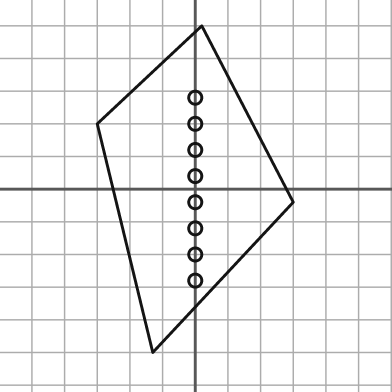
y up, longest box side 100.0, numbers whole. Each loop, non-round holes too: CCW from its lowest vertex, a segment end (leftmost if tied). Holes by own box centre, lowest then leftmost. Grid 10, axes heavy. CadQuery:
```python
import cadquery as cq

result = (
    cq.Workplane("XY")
    .moveTo(-13.0, -50.0)
    .lineTo(30.0, -4.0)
    .lineTo(2.0, 50.0)
    .lineTo(-30.0, 20.0)
    .close()
    .moveTo(0.0, -28.0)
    .circle(2.0)
    .moveTo(0.0, -20.0)
    .circle(2.0)
    .moveTo(0.0, -12.0)
    .circle(2.0)
    .moveTo(0.0, -4.0)
    .circle(2.0)
    .moveTo(0.0, 4.0)
    .circle(2.0)
    .moveTo(0.0, 12.0)
    .circle(2.0)
    .moveTo(0.0, 20.0)
    .circle(2.0)
    .moveTo(0.0, 28.0)
    .circle(2.0)
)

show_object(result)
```